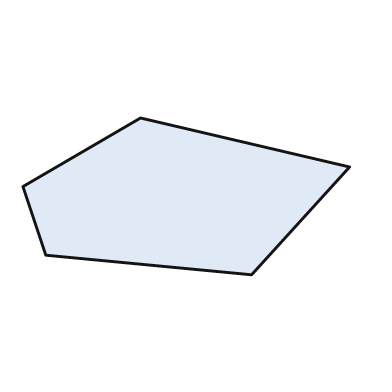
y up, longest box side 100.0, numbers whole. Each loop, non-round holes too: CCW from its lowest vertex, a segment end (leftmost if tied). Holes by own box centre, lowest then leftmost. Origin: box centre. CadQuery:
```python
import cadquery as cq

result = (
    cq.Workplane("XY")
    .moveTo(20.0, -24.0)
    .lineTo(50.0, 9.0)
    .lineTo(-14.0, 24.0)
    .lineTo(-50.0, 3.0)
    .lineTo(-43.0, -18.0)
    .close()
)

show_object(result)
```